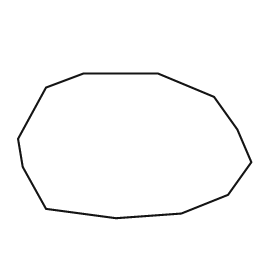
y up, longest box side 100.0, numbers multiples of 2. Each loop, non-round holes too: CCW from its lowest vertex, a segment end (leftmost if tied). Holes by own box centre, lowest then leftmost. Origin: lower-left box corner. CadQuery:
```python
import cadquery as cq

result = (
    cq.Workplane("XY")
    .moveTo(42.0, 0.0)
    .lineTo(70.0, 2.0)
    .lineTo(90.0, 10.0)
    .lineTo(100.0, 24.0)
    .lineTo(94.0, 38.0)
    .lineTo(84.0, 52.0)
    .lineTo(60.0, 62.0)
    .lineTo(28.0, 62.0)
    .lineTo(12.0, 56.0)
    .lineTo(0.0, 34.0)
    .lineTo(2.0, 22.0)
    .lineTo(12.0, 4.0)
    .close()
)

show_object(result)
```